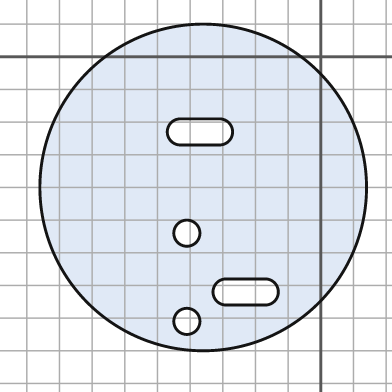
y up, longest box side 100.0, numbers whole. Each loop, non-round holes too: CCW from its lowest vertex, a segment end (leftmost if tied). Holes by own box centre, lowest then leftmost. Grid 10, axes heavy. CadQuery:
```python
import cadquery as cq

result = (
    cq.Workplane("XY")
    .moveTo(-36.0, -40.0)
    .circle(50.0)
    .moveTo(-41.0, -81.0)
    .circle(4.0)
    .moveTo(-29.0, -76.0)
    .lineTo(-17.0, -76.0)
    .threePointArc((-13.0, -72.0), (-17.0, -68.0))
    .lineTo(-29.0, -68.0)
    .threePointArc((-33.0, -72.0), (-29.0, -76.0))
    .close()
    .moveTo(-41.0, -54.0)
    .circle(4.0)
    .moveTo(-43.0, -27.0)
    .lineTo(-31.0, -27.0)
    .threePointArc((-27.0, -23.0), (-31.0, -19.0))
    .lineTo(-43.0, -19.0)
    .threePointArc((-47.0, -23.0), (-43.0, -27.0))
    .close()
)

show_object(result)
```